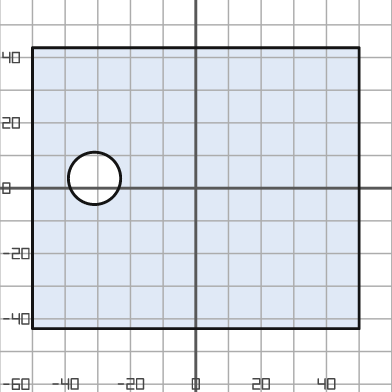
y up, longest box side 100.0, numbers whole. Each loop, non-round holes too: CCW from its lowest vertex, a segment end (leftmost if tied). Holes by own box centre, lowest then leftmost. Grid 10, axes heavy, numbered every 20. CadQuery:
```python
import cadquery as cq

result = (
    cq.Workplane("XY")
    .moveTo(-50.0, -43.0)
    .lineTo(50.0, -43.0)
    .lineTo(50.0, 43.0)
    .lineTo(-50.0, 43.0)
    .close()
    .moveTo(-31.0, 3.0)
    .circle(8.0)
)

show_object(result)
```